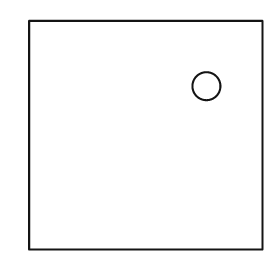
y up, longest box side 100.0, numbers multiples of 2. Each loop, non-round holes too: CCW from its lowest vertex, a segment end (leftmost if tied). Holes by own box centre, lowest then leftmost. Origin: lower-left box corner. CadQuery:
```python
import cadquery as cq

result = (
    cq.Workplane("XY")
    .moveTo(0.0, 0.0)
    .lineTo(100.0, 0.0)
    .lineTo(100.0, 98.0)
    .lineTo(0.0, 98.0)
    .close()
    .moveTo(76.0, 70.0)
    .circle(6.0)
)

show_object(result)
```